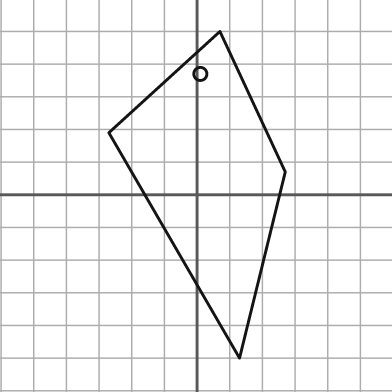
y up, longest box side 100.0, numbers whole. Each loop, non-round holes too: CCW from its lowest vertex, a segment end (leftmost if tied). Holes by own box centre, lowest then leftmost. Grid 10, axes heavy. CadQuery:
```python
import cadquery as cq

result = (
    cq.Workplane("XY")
    .moveTo(13.0, -50.0)
    .lineTo(27.0, 7.0)
    .lineTo(7.0, 50.0)
    .lineTo(-27.0, 19.0)
    .close()
    .moveTo(1.0, 37.0)
    .circle(2.0)
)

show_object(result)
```